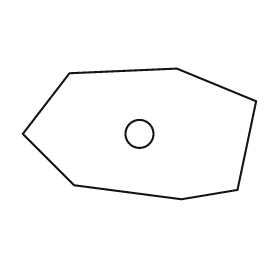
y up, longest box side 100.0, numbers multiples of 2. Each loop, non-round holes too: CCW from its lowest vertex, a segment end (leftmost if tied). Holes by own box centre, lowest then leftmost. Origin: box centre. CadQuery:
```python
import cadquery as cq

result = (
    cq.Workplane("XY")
    .moveTo(18.0, -28.0)
    .lineTo(42.0, -24.0)
    .lineTo(50.0, 14.0)
    .lineTo(16.0, 28.0)
    .lineTo(-30.0, 26.0)
    .lineTo(-50.0, 0.0)
    .lineTo(-28.0, -22.0)
    .close()
    .moveTo(0.0, 0.0)
    .circle(6.0)
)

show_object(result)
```